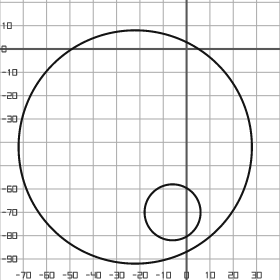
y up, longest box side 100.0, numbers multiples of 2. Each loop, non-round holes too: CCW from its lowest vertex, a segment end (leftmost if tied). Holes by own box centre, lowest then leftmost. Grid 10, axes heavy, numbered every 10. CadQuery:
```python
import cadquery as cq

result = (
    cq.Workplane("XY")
    .moveTo(-22.0, -42.0)
    .circle(50.0)
    .moveTo(-6.0, -70.0)
    .circle(12.0)
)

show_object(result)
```